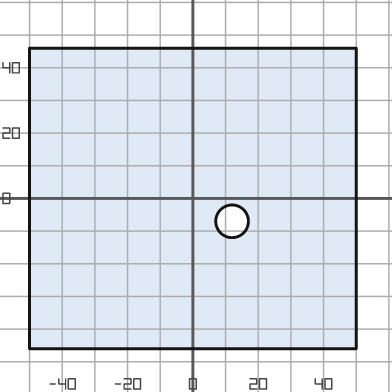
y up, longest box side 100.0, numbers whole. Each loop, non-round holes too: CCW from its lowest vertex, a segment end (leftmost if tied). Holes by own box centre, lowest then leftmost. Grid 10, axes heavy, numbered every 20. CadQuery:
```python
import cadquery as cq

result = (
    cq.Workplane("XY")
    .moveTo(-50.0, -46.0)
    .lineTo(50.0, -46.0)
    .lineTo(50.0, 46.0)
    .lineTo(-50.0, 46.0)
    .close()
    .moveTo(12.0, -7.0)
    .circle(5.0)
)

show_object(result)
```